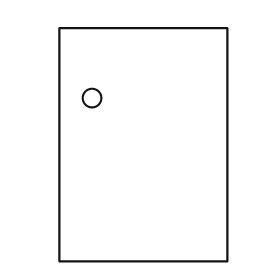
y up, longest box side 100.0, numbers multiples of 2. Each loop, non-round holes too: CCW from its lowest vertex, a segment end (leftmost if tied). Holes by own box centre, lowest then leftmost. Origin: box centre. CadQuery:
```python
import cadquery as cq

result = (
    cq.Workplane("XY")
    .moveTo(-36.0, -50.0)
    .lineTo(36.0, -50.0)
    .lineTo(36.0, 50.0)
    .lineTo(-36.0, 50.0)
    .close()
    .moveTo(-22.0, 20.0)
    .circle(4.0)
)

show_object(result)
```